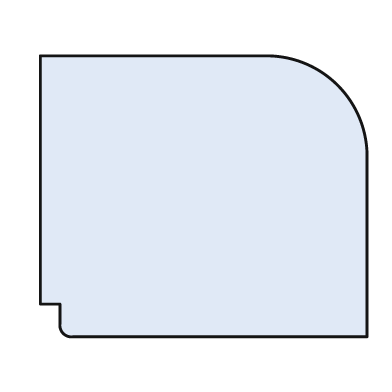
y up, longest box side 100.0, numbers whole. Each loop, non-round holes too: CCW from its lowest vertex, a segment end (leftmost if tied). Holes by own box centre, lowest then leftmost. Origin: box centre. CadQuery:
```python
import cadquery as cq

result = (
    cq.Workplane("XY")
    .moveTo(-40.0, -43.0)
    .lineTo(50.0, -43.0)
    .lineTo(50.0, 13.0)
    .threePointArc((41.0, 34.0), (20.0, 43.0))
    .lineTo(-50.0, 43.0)
    .lineTo(-50.0, -33.0)
    .lineTo(-44.0, -33.0)
    .lineTo(-44.0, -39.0)
    .threePointArc((-43.0, -42.0), (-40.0, -43.0))
    .close()
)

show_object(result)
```